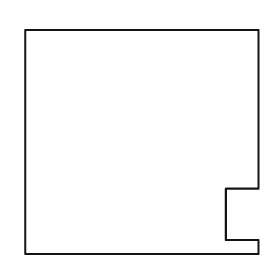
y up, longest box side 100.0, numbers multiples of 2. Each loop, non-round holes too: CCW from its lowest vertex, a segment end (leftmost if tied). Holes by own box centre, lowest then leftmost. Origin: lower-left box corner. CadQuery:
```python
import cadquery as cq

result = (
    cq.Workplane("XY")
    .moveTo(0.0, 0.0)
    .lineTo(100.0, 0.0)
    .lineTo(100.0, 6.0)
    .lineTo(86.0, 6.0)
    .lineTo(86.0, 28.0)
    .lineTo(100.0, 28.0)
    .lineTo(100.0, 96.0)
    .lineTo(0.0, 96.0)
    .close()
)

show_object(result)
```